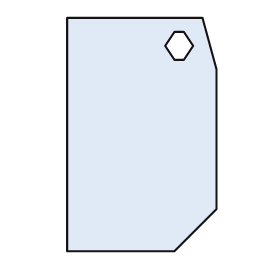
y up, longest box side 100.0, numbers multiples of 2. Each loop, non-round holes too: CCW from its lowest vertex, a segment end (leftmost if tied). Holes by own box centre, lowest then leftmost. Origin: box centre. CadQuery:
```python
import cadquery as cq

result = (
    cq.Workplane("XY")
    .moveTo(-32.0, -50.0)
    .lineTo(14.0, -50.0)
    .lineTo(32.0, -32.0)
    .lineTo(32.0, 28.0)
    .lineTo(26.0, 50.0)
    .lineTo(-32.0, 50.0)
    .close()
    .moveTo(14.0, 32.0)
    .lineTo(18.0, 32.0)
    .lineTo(22.0, 38.0)
    .lineTo(18.0, 44.0)
    .lineTo(14.0, 44.0)
    .lineTo(10.0, 38.0)
    .close()
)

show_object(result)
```